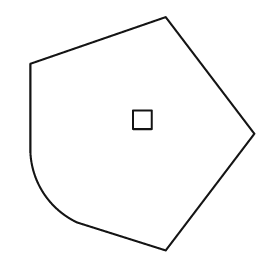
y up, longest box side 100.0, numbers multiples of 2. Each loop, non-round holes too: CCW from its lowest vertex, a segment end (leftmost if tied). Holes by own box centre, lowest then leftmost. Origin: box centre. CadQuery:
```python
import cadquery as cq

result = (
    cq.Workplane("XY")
    .moveTo(10.0, -50.0)
    .lineTo(48.0, 0.0)
    .lineTo(10.0, 50.0)
    .lineTo(-48.0, 30.0)
    .lineTo(-48.0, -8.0)
    .threePointArc((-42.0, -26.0), (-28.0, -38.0))
    .close()
    .moveTo(-4.0, 2.0)
    .lineTo(4.0, 2.0)
    .lineTo(4.0, 10.0)
    .lineTo(-4.0, 10.0)
    .close()
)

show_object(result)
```